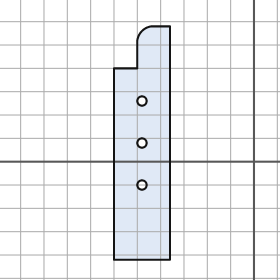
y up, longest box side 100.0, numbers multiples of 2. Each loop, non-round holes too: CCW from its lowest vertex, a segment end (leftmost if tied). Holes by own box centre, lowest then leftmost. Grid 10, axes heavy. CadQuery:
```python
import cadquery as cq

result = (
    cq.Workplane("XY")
    .moveTo(-60.0, -42.0)
    .lineTo(-36.0, -42.0)
    .lineTo(-36.0, 58.0)
    .lineTo(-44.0, 58.0)
    .threePointArc((-48.0, 56.0), (-50.0, 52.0))
    .lineTo(-50.0, 40.0)
    .lineTo(-60.0, 40.0)
    .close()
    .moveTo(-48.0, -10.0)
    .circle(2.0)
    .moveTo(-48.0, 8.0)
    .circle(2.0)
    .moveTo(-48.0, 26.0)
    .circle(2.0)
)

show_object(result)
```